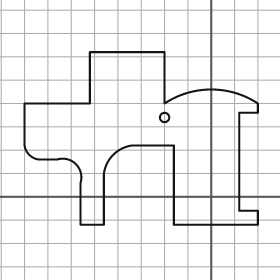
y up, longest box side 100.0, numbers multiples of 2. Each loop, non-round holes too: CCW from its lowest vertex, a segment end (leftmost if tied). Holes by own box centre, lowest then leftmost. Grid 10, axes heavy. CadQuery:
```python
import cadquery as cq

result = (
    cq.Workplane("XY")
    .moveTo(-56.0, -12.0)
    .lineTo(-46.0, -12.0)
    .lineTo(-46.0, 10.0)
    .threePointArc((-42.0, 18.0), (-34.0, 22.0))
    .lineTo(-16.0, 22.0)
    .lineTo(-16.0, -12.0)
    .lineTo(20.0, -12.0)
    .lineTo(20.0, -6.0)
    .lineTo(12.0, -6.0)
    .lineTo(12.0, 36.0)
    .lineTo(20.0, 36.0)
    .lineTo(20.0, 40.0)
    .threePointArc((0.0, 46.0), (-20.0, 40.0))
    .lineTo(-20.0, 62.0)
    .lineTo(-52.0, 62.0)
    .lineTo(-52.0, 40.0)
    .lineTo(-80.0, 40.0)
    .lineTo(-80.0, 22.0)
    .threePointArc((-78.0, 18.0), (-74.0, 16.0))
    .lineTo(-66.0, 16.0)
    .threePointArc((-58.0, 14.0), (-56.0, 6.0))
    .close()
    .moveTo(-20.0, 34.0)
    .circle(2.0)
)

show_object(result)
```